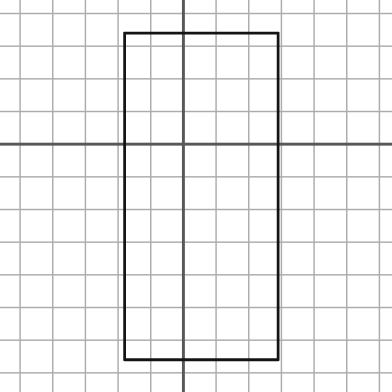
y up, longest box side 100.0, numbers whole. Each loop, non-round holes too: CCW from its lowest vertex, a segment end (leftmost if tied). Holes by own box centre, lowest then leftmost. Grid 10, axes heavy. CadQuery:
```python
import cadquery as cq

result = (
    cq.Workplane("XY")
    .moveTo(-18.0, -66.0)
    .lineTo(29.0, -66.0)
    .lineTo(29.0, 34.0)
    .lineTo(-18.0, 34.0)
    .close()
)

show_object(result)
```